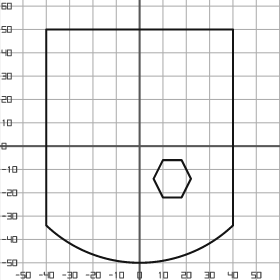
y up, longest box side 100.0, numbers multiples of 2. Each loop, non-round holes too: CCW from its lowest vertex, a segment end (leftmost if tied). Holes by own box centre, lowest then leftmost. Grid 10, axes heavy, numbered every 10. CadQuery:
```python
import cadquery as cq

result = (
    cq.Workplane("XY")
    .moveTo(-40.0, -34.0)
    .threePointArc((0.0, -50.0), (40.0, -34.0))
    .lineTo(40.0, 50.0)
    .lineTo(-40.0, 50.0)
    .close()
    .moveTo(10.0, -22.0)
    .lineTo(18.0, -22.0)
    .lineTo(22.0, -14.0)
    .lineTo(18.0, -6.0)
    .lineTo(10.0, -6.0)
    .lineTo(6.0, -14.0)
    .close()
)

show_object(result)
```